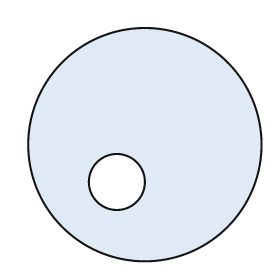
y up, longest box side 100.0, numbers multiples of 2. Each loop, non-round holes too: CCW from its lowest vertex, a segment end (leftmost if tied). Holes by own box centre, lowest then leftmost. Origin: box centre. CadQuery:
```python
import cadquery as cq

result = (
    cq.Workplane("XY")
    .moveTo(0.0, 0.0)
    .circle(50.0)
    .moveTo(-12.0, -16.0)
    .circle(12.0)
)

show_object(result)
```